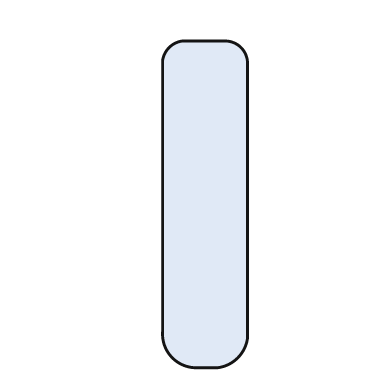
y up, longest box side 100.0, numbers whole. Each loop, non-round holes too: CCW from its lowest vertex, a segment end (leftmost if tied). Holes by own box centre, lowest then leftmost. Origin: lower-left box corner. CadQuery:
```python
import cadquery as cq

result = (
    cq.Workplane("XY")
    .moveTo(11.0, 0.0)
    .lineTo(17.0, 0.0)
    .threePointArc((23.0, 3.0), (26.0, 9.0))
    .lineTo(26.0, 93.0)
    .threePointArc((24.0, 98.0), (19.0, 100.0))
    .lineTo(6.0, 100.0)
    .threePointArc((2.0, 98.0), (0.0, 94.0))
    .lineTo(0.0, 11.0)
    .threePointArc((3.0, 3.0), (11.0, 0.0))
    .close()
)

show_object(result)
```